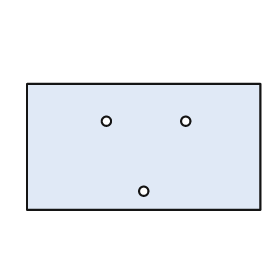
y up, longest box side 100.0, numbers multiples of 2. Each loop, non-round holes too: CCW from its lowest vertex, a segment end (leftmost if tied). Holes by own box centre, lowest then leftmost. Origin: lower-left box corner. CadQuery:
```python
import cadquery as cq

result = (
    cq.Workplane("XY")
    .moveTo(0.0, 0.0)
    .lineTo(100.0, 0.0)
    .lineTo(100.0, 54.0)
    .lineTo(0.0, 54.0)
    .close()
    .moveTo(50.0, 8.0)
    .circle(2.0)
    .moveTo(34.0, 38.0)
    .circle(2.0)
    .moveTo(68.0, 38.0)
    .circle(2.0)
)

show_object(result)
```